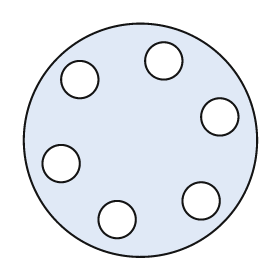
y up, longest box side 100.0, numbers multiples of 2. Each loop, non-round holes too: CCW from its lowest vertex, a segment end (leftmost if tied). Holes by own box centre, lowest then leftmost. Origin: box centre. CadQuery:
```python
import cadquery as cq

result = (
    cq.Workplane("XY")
    .moveTo(0.0, 0.0)
    .circle(50.0)
    .moveTo(-10.0, -34.0)
    .circle(8.0)
    .moveTo(26.0, -26.0)
    .circle(8.0)
    .moveTo(-34.0, -10.0)
    .circle(8.0)
    .moveTo(34.0, 10.0)
    .circle(8.0)
    .moveTo(-26.0, 26.0)
    .circle(8.0)
    .moveTo(10.0, 34.0)
    .circle(8.0)
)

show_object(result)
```